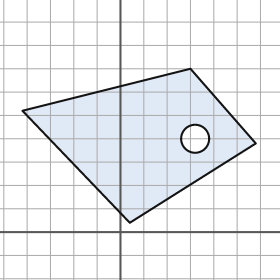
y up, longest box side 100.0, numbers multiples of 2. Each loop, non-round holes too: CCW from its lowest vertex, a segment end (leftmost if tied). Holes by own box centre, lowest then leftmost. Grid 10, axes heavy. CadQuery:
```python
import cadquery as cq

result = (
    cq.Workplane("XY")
    .moveTo(4.0, 4.0)
    .lineTo(58.0, 38.0)
    .lineTo(30.0, 70.0)
    .lineTo(-42.0, 52.0)
    .close()
    .moveTo(32.0, 40.0)
    .circle(6.0)
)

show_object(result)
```